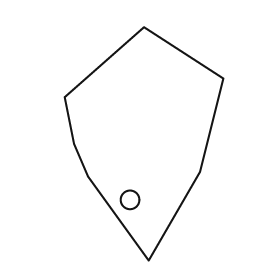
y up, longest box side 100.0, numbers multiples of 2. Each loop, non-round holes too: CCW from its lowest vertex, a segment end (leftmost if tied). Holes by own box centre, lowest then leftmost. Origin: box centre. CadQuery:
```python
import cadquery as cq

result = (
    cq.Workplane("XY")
    .moveTo(2.0, -50.0)
    .lineTo(24.0, -12.0)
    .lineTo(34.0, 28.0)
    .lineTo(0.0, 50.0)
    .lineTo(-34.0, 20.0)
    .lineTo(-30.0, 0.0)
    .lineTo(-24.0, -14.0)
    .close()
    .moveTo(-6.0, -24.0)
    .circle(4.0)
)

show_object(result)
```